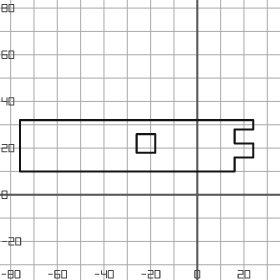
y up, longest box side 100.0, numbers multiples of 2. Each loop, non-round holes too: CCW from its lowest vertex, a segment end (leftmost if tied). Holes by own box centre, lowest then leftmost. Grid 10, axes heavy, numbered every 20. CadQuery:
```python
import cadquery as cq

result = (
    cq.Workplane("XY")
    .moveTo(-76.0, 10.0)
    .lineTo(16.0, 10.0)
    .lineTo(16.0, 16.0)
    .lineTo(24.0, 16.0)
    .lineTo(24.0, 22.0)
    .lineTo(16.0, 22.0)
    .lineTo(16.0, 28.0)
    .lineTo(24.0, 28.0)
    .lineTo(24.0, 32.0)
    .lineTo(-76.0, 32.0)
    .close()
    .moveTo(-26.0, 18.0)
    .lineTo(-18.0, 18.0)
    .lineTo(-18.0, 26.0)
    .lineTo(-26.0, 26.0)
    .close()
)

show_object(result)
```